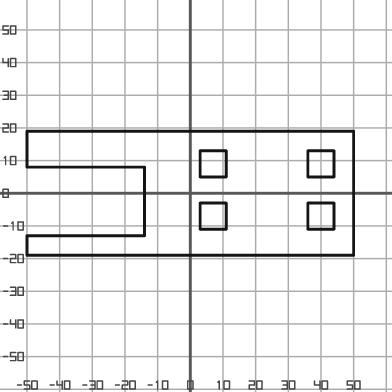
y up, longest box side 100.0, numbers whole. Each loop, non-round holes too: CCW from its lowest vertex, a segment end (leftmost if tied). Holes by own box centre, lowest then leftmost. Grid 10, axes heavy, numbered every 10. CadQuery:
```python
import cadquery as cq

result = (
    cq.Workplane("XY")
    .moveTo(-50.0, -19.0)
    .lineTo(50.0, -19.0)
    .lineTo(50.0, 19.0)
    .lineTo(-50.0, 19.0)
    .lineTo(-50.0, 8.0)
    .lineTo(-14.0, 8.0)
    .lineTo(-14.0, -13.0)
    .lineTo(-50.0, -13.0)
    .close()
    .moveTo(3.0, -11.0)
    .lineTo(11.0, -11.0)
    .lineTo(11.0, -3.0)
    .lineTo(3.0, -3.0)
    .close()
    .moveTo(36.0, -11.0)
    .lineTo(44.0, -11.0)
    .lineTo(44.0, -3.0)
    .lineTo(36.0, -3.0)
    .close()
    .moveTo(3.0, 5.0)
    .lineTo(11.0, 5.0)
    .lineTo(11.0, 13.0)
    .lineTo(3.0, 13.0)
    .close()
    .moveTo(36.0, 5.0)
    .lineTo(44.0, 5.0)
    .lineTo(44.0, 13.0)
    .lineTo(36.0, 13.0)
    .close()
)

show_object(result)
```